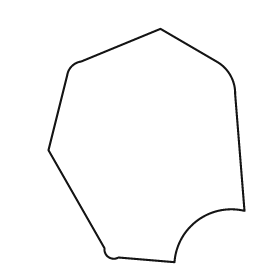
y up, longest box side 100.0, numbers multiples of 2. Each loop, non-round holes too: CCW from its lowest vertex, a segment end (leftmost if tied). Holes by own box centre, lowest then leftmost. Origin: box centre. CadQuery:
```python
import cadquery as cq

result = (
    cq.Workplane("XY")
    .moveTo(12.0, -50.0)
    .threePointArc((22.0, -32.0), (42.0, -28.0))
    .lineTo(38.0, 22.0)
    .threePointArc((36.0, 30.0), (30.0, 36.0))
    .lineTo(6.0, 50.0)
    .lineTo(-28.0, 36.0)
    .threePointArc((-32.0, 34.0), (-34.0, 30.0))
    .lineTo(-42.0, -2.0)
    .lineTo(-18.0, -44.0)
    .threePointArc((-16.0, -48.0), (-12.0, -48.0))
    .close()
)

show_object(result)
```